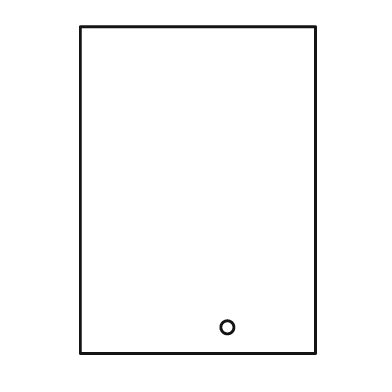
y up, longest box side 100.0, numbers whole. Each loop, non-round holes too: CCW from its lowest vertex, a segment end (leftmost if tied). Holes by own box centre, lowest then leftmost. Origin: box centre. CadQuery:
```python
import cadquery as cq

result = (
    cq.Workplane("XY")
    .moveTo(-36.0, -50.0)
    .lineTo(36.0, -50.0)
    .lineTo(36.0, 50.0)
    .lineTo(-36.0, 50.0)
    .close()
    .moveTo(9.0, -42.0)
    .circle(2.0)
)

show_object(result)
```